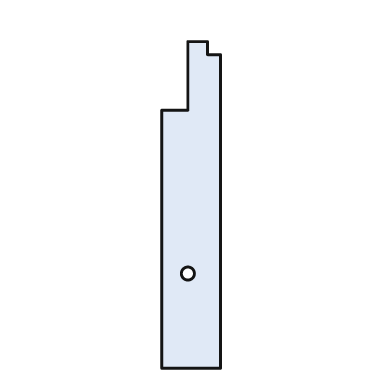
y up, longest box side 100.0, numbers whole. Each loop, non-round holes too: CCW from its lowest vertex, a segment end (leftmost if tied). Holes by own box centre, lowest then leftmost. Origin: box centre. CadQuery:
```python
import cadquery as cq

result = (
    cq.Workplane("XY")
    .moveTo(-9.0, -50.0)
    .lineTo(9.0, -50.0)
    .lineTo(9.0, 46.0)
    .lineTo(5.0, 46.0)
    .lineTo(5.0, 50.0)
    .lineTo(-1.0, 50.0)
    .lineTo(-1.0, 29.0)
    .lineTo(-9.0, 29.0)
    .close()
    .moveTo(-1.0, -21.0)
    .circle(2.0)
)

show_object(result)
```